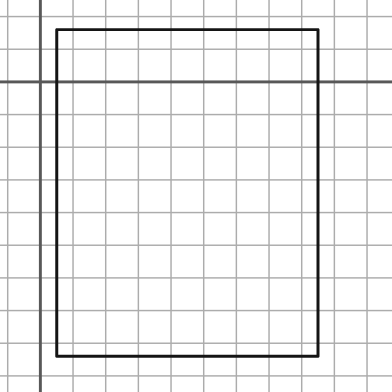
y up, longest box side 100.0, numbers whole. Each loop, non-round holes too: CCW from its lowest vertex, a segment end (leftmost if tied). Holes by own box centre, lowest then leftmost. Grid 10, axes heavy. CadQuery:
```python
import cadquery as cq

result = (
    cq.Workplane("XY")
    .moveTo(5.0, -84.0)
    .lineTo(85.0, -84.0)
    .lineTo(85.0, 16.0)
    .lineTo(5.0, 16.0)
    .close()
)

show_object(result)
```